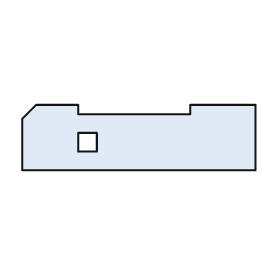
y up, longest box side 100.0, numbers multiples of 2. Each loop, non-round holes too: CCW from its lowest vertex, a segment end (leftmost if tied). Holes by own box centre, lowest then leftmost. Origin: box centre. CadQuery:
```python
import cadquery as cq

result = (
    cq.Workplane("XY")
    .moveTo(-50.0, -14.0)
    .lineTo(50.0, -14.0)
    .lineTo(50.0, 14.0)
    .lineTo(22.0, 14.0)
    .lineTo(22.0, 10.0)
    .lineTo(-26.0, 10.0)
    .lineTo(-26.0, 14.0)
    .lineTo(-44.0, 14.0)
    .lineTo(-50.0, 8.0)
    .close()
    .moveTo(-26.0, -6.0)
    .lineTo(-18.0, -6.0)
    .lineTo(-18.0, 2.0)
    .lineTo(-26.0, 2.0)
    .close()
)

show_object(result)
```